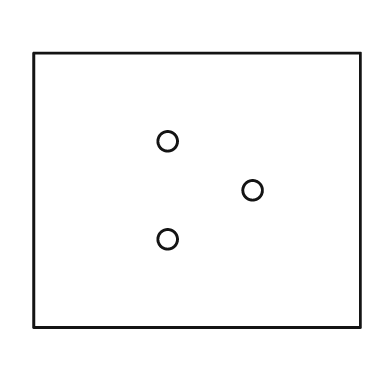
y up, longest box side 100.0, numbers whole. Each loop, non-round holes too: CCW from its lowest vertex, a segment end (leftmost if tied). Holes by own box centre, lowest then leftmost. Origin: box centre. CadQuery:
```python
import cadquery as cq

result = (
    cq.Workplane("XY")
    .moveTo(-50.0, -42.0)
    .lineTo(50.0, -42.0)
    .lineTo(50.0, 42.0)
    .lineTo(-50.0, 42.0)
    .close()
    .moveTo(-9.0, -15.0)
    .circle(3.0)
    .moveTo(17.0, 0.0)
    .circle(3.0)
    .moveTo(-9.0, 15.0)
    .circle(3.0)
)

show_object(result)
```